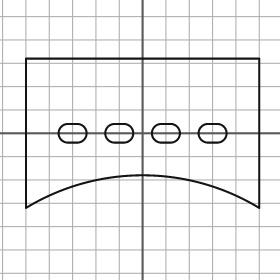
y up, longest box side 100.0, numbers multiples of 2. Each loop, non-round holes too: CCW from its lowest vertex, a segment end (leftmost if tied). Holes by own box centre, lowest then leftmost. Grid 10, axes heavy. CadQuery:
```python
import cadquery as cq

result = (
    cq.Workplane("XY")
    .moveTo(-50.0, -32.0)
    .threePointArc((0.0, -18.0), (50.0, -32.0))
    .lineTo(50.0, 32.0)
    .lineTo(-50.0, 32.0)
    .close()
    .moveTo(-32.0, -4.0)
    .lineTo(-28.0, -4.0)
    .threePointArc((-24.0, 0.0), (-28.0, 4.0))
    .lineTo(-32.0, 4.0)
    .threePointArc((-36.0, 0.0), (-32.0, -4.0))
    .close()
    .moveTo(-12.0, -4.0)
    .lineTo(-8.0, -4.0)
    .threePointArc((-4.0, 0.0), (-8.0, 4.0))
    .lineTo(-12.0, 4.0)
    .threePointArc((-16.0, 0.0), (-12.0, -4.0))
    .close()
    .moveTo(8.0, -4.0)
    .lineTo(12.0, -4.0)
    .threePointArc((16.0, 0.0), (12.0, 4.0))
    .lineTo(8.0, 4.0)
    .threePointArc((4.0, 0.0), (8.0, -4.0))
    .close()
    .moveTo(28.0, -4.0)
    .lineTo(32.0, -4.0)
    .threePointArc((36.0, 0.0), (32.0, 4.0))
    .lineTo(28.0, 4.0)
    .threePointArc((24.0, 0.0), (28.0, -4.0))
    .close()
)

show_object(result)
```